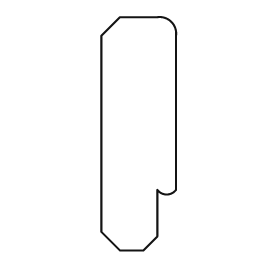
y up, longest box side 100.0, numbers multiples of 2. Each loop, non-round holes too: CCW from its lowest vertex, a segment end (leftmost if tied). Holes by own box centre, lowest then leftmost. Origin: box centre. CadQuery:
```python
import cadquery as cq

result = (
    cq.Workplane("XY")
    .moveTo(-8.0, -50.0)
    .lineTo(2.0, -50.0)
    .lineTo(8.0, -44.0)
    .lineTo(8.0, -24.0)
    .threePointArc((12.0, -26.0), (16.0, -24.0))
    .lineTo(16.0, 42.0)
    .threePointArc((14.0, 48.0), (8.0, 50.0))
    .lineTo(-8.0, 50.0)
    .lineTo(-16.0, 42.0)
    .lineTo(-16.0, -42.0)
    .close()
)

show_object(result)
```